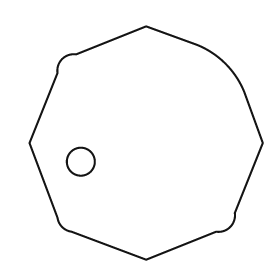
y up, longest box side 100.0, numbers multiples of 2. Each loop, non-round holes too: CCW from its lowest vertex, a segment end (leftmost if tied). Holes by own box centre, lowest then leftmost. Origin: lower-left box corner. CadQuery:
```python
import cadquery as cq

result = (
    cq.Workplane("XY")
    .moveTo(50.0, 0.0)
    .lineTo(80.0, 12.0)
    .threePointArc((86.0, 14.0), (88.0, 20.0))
    .lineTo(100.0, 50.0)
    .lineTo(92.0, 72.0)
    .threePointArc((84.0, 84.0), (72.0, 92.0))
    .lineTo(50.0, 100.0)
    .lineTo(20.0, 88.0)
    .threePointArc((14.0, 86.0), (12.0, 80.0))
    .lineTo(0.0, 50.0)
    .lineTo(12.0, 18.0)
    .threePointArc((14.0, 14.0), (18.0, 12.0))
    .close()
    .moveTo(22.0, 42.0)
    .circle(6.0)
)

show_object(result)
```